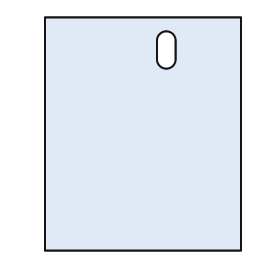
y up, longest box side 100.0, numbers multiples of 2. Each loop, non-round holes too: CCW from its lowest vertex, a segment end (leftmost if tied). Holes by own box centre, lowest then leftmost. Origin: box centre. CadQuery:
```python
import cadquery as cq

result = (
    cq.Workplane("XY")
    .moveTo(-42.0, -50.0)
    .lineTo(42.0, -50.0)
    .lineTo(42.0, 50.0)
    .lineTo(-42.0, 50.0)
    .close()
    .moveTo(6.0, 32.0)
    .threePointArc((10.0, 28.0), (14.0, 32.0))
    .lineTo(14.0, 40.0)
    .threePointArc((10.0, 44.0), (6.0, 40.0))
    .close()
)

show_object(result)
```